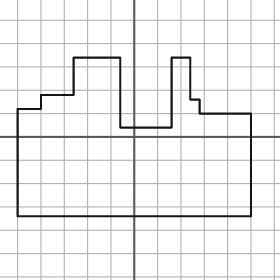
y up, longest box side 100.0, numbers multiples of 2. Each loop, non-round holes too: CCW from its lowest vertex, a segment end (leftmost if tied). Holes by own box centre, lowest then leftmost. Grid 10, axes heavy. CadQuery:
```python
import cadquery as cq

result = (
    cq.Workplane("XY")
    .moveTo(-50.0, -34.0)
    .lineTo(50.0, -34.0)
    .lineTo(50.0, 10.0)
    .lineTo(28.0, 10.0)
    .lineTo(28.0, 16.0)
    .lineTo(24.0, 16.0)
    .lineTo(24.0, 34.0)
    .lineTo(16.0, 34.0)
    .lineTo(16.0, 4.0)
    .lineTo(-6.0, 4.0)
    .lineTo(-6.0, 34.0)
    .lineTo(-26.0, 34.0)
    .lineTo(-26.0, 18.0)
    .lineTo(-40.0, 18.0)
    .lineTo(-40.0, 12.0)
    .lineTo(-50.0, 12.0)
    .close()
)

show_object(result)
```